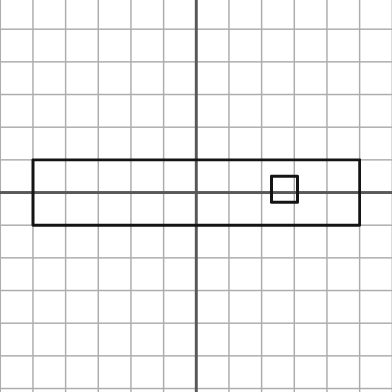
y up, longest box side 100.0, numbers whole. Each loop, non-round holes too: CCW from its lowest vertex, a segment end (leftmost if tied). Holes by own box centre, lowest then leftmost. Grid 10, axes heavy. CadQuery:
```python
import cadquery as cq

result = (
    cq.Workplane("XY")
    .moveTo(-50.0, -10.0)
    .lineTo(50.0, -10.0)
    .lineTo(50.0, 10.0)
    .lineTo(-50.0, 10.0)
    .close()
    .moveTo(23.0, -3.0)
    .lineTo(31.0, -3.0)
    .lineTo(31.0, 5.0)
    .lineTo(23.0, 5.0)
    .close()
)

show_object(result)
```